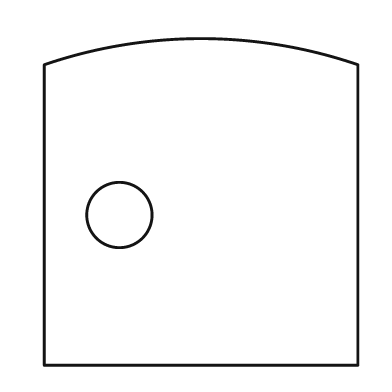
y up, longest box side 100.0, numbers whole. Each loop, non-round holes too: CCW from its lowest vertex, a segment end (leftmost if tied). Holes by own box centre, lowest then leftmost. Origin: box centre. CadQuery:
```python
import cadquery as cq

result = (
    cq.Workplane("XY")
    .moveTo(-48.0, -50.0)
    .lineTo(48.0, -50.0)
    .lineTo(48.0, 42.0)
    .threePointArc((0.0, 50.0), (-48.0, 42.0))
    .close()
    .moveTo(-25.0, -4.0)
    .circle(10.0)
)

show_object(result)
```